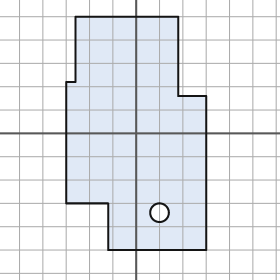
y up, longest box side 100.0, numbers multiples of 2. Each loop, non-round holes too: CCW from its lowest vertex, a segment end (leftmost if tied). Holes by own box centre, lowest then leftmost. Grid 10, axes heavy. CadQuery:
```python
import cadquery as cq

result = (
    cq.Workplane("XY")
    .moveTo(-12.0, -50.0)
    .lineTo(30.0, -50.0)
    .lineTo(30.0, 16.0)
    .lineTo(18.0, 16.0)
    .lineTo(18.0, 50.0)
    .lineTo(-26.0, 50.0)
    .lineTo(-26.0, 22.0)
    .lineTo(-30.0, 22.0)
    .lineTo(-30.0, -30.0)
    .lineTo(-12.0, -30.0)
    .close()
    .moveTo(10.0, -34.0)
    .circle(4.0)
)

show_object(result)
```